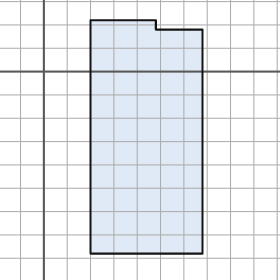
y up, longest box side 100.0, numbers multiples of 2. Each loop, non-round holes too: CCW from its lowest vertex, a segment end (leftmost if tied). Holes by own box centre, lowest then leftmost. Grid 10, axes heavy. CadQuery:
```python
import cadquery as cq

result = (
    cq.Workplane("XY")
    .moveTo(20.0, -78.0)
    .lineTo(68.0, -78.0)
    .lineTo(68.0, 18.0)
    .lineTo(48.0, 18.0)
    .lineTo(48.0, 22.0)
    .lineTo(20.0, 22.0)
    .close()
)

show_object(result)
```